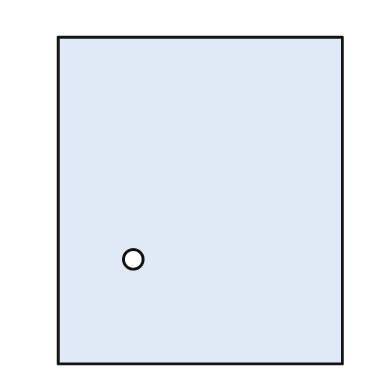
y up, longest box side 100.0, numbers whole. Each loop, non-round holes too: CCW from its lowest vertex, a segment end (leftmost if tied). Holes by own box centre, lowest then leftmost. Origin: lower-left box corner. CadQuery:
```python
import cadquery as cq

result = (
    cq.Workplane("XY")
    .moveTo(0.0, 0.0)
    .lineTo(87.0, 0.0)
    .lineTo(87.0, 100.0)
    .lineTo(0.0, 100.0)
    .close()
    .moveTo(23.0, 32.0)
    .circle(3.0)
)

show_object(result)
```